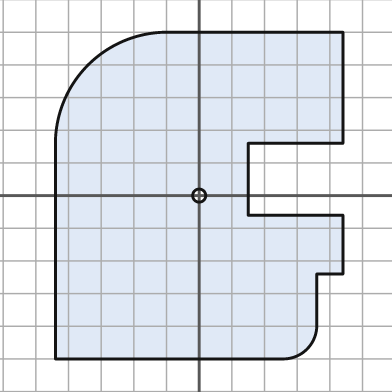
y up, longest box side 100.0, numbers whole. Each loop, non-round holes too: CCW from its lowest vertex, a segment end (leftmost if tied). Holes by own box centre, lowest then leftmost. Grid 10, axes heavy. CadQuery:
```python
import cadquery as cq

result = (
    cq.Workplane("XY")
    .moveTo(-44.0, -50.0)
    .lineTo(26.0, -50.0)
    .threePointArc((33.0, -47.0), (36.0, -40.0))
    .lineTo(36.0, -24.0)
    .lineTo(44.0, -24.0)
    .lineTo(44.0, -6.0)
    .lineTo(15.0, -6.0)
    .lineTo(15.0, 16.0)
    .lineTo(44.0, 16.0)
    .lineTo(44.0, 50.0)
    .lineTo(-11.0, 50.0)
    .threePointArc((-34.0, 40.0), (-44.0, 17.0))
    .close()
    .moveTo(0.0, 0.0)
    .circle(2.0)
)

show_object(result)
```